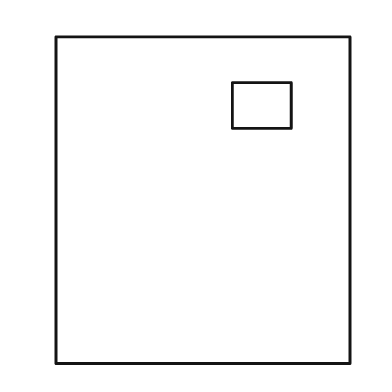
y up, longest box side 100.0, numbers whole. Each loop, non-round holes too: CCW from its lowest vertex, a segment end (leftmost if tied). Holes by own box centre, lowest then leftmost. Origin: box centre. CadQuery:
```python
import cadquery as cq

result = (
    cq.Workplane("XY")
    .moveTo(-45.0, -50.0)
    .lineTo(45.0, -50.0)
    .lineTo(45.0, 50.0)
    .lineTo(-45.0, 50.0)
    .close()
    .moveTo(9.0, 22.0)
    .lineTo(27.0, 22.0)
    .lineTo(27.0, 36.0)
    .lineTo(9.0, 36.0)
    .close()
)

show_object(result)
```